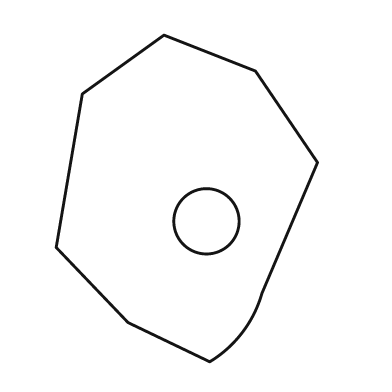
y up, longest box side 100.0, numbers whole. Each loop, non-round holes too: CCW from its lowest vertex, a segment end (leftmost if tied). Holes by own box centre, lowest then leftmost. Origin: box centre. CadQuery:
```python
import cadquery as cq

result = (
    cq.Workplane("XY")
    .moveTo(7.0, -50.0)
    .threePointArc((17.0, -41.0), (23.0, -29.0))
    .lineTo(40.0, 11.0)
    .lineTo(21.0, 39.0)
    .lineTo(-7.0, 50.0)
    .lineTo(-32.0, 32.0)
    .lineTo(-40.0, -15.0)
    .lineTo(-18.0, -38.0)
    .close()
    .moveTo(6.0, -7.0)
    .circle(10.0)
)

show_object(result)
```